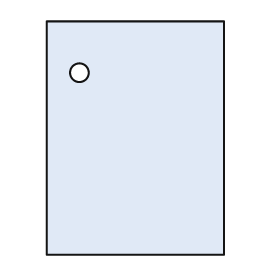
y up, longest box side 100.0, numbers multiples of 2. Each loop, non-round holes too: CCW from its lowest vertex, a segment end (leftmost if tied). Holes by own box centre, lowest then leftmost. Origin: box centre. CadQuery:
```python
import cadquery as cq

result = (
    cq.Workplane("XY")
    .moveTo(-38.0, -50.0)
    .lineTo(38.0, -50.0)
    .lineTo(38.0, 50.0)
    .lineTo(-38.0, 50.0)
    .close()
    .moveTo(-24.0, 28.0)
    .circle(4.0)
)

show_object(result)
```